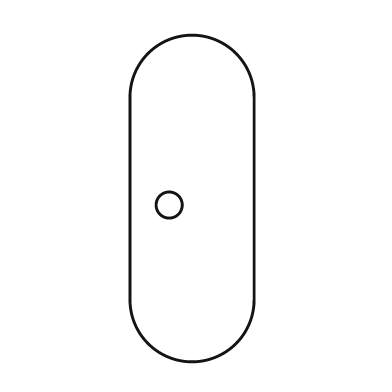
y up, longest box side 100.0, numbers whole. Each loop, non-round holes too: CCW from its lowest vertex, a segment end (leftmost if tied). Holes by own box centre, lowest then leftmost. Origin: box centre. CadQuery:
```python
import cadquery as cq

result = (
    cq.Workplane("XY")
    .moveTo(-19.0, -31.0)
    .threePointArc((0.0, -50.0), (19.0, -31.0))
    .lineTo(19.0, 31.0)
    .threePointArc((0.0, 50.0), (-19.0, 31.0))
    .close()
    .moveTo(-7.0, -2.0)
    .circle(4.0)
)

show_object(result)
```